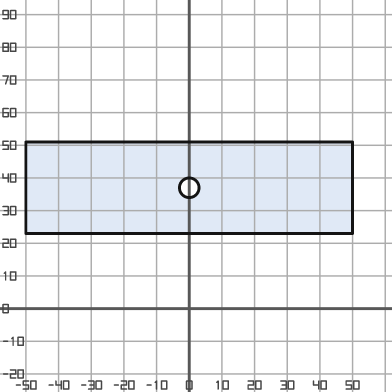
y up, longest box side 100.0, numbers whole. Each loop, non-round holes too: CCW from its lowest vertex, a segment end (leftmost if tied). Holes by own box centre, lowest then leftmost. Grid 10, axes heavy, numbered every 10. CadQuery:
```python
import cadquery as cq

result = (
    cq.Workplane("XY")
    .moveTo(-50.0, 23.0)
    .lineTo(50.0, 23.0)
    .lineTo(50.0, 51.0)
    .lineTo(-50.0, 51.0)
    .close()
    .moveTo(0.0, 37.0)
    .circle(3.0)
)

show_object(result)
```